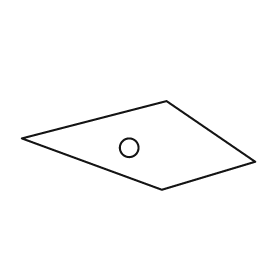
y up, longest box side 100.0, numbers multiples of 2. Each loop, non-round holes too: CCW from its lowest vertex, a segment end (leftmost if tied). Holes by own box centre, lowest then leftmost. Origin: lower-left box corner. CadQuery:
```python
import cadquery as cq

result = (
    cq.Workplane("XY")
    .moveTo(60.0, 0.0)
    .lineTo(100.0, 12.0)
    .lineTo(62.0, 38.0)
    .lineTo(0.0, 22.0)
    .close()
    .moveTo(46.0, 18.0)
    .circle(4.0)
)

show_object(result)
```